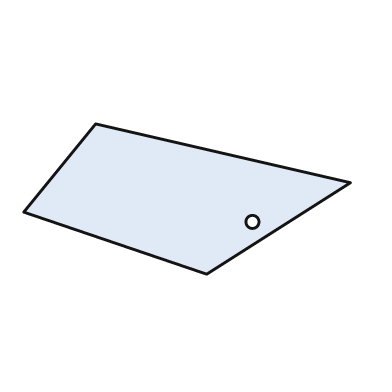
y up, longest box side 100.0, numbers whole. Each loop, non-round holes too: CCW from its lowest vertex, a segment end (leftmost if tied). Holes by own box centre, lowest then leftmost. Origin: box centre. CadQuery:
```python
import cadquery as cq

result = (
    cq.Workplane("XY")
    .moveTo(6.0, -23.0)
    .lineTo(50.0, 5.0)
    .lineTo(-28.0, 23.0)
    .lineTo(-50.0, -4.0)
    .close()
    .moveTo(20.0, -7.0)
    .circle(2.0)
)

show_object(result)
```